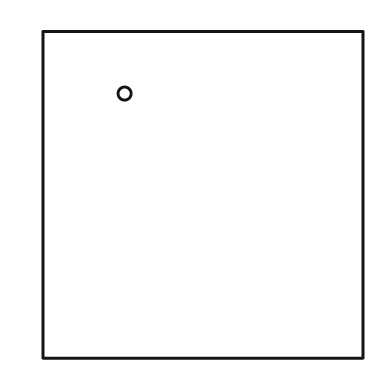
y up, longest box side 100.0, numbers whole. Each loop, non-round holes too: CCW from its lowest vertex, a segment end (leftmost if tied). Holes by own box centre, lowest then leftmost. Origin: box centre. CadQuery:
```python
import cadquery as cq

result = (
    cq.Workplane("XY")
    .moveTo(-49.0, -50.0)
    .lineTo(49.0, -50.0)
    .lineTo(49.0, 50.0)
    .lineTo(-49.0, 50.0)
    .close()
    .moveTo(-24.0, 31.0)
    .circle(2.0)
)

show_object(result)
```